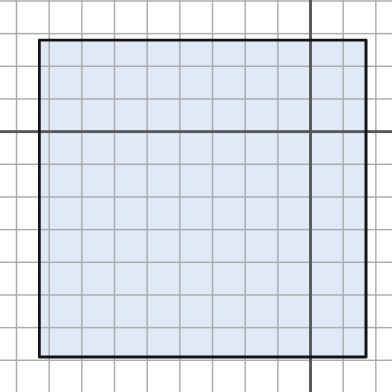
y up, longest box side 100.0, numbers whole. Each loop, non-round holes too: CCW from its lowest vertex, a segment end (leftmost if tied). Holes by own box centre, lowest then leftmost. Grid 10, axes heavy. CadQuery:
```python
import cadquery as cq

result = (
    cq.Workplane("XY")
    .moveTo(-83.0, -69.0)
    .lineTo(17.0, -69.0)
    .lineTo(17.0, 28.0)
    .lineTo(-83.0, 28.0)
    .close()
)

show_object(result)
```